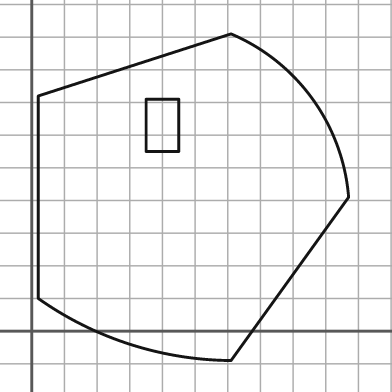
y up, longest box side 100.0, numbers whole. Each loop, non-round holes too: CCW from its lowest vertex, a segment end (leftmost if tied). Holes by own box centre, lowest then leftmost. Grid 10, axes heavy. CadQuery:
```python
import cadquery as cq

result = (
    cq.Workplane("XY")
    .moveTo(61.0, -9.0)
    .lineTo(97.0, 41.0)
    .threePointArc((86.0, 71.0), (61.0, 91.0))
    .lineTo(2.0, 72.0)
    .lineTo(2.0, 10.0)
    .threePointArc((30.0, -4.0), (61.0, -9.0))
    .close()
    .moveTo(35.0, 55.0)
    .lineTo(45.0, 55.0)
    .lineTo(45.0, 71.0)
    .lineTo(35.0, 71.0)
    .close()
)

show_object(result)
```